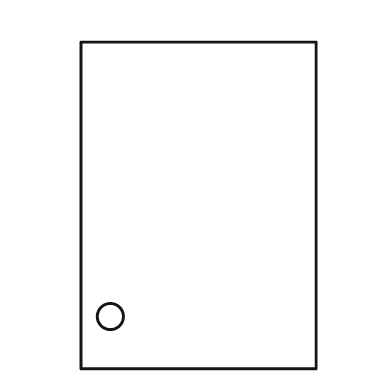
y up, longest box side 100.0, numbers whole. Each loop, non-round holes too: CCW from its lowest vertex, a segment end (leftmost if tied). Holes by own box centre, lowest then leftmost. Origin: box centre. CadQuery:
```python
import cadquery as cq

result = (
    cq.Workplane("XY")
    .moveTo(-36.0, -50.0)
    .lineTo(36.0, -50.0)
    .lineTo(36.0, 50.0)
    .lineTo(-36.0, 50.0)
    .close()
    .moveTo(-27.0, -34.0)
    .circle(4.0)
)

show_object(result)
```